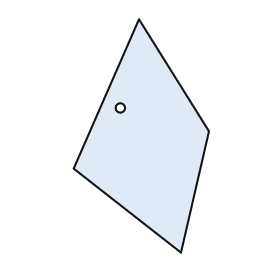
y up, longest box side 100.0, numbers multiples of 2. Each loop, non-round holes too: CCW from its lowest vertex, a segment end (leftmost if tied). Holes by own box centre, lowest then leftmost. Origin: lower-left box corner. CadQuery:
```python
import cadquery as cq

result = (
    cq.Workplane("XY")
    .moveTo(46.0, 0.0)
    .lineTo(58.0, 52.0)
    .lineTo(28.0, 100.0)
    .lineTo(0.0, 36.0)
    .close()
    .moveTo(20.0, 62.0)
    .circle(2.0)
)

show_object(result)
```